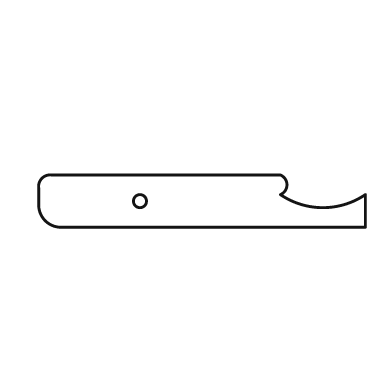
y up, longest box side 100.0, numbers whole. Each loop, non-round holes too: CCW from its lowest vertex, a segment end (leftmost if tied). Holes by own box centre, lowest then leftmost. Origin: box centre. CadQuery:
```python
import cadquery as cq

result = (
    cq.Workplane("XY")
    .moveTo(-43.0, -8.0)
    .lineTo(50.0, -8.0)
    .lineTo(50.0, 2.0)
    .threePointArc((37.0, -2.0), (24.0, 2.0))
    .threePointArc((26.0, 5.0), (24.0, 8.0))
    .lineTo(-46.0, 8.0)
    .threePointArc((-49.0, 7.0), (-50.0, 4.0))
    .lineTo(-50.0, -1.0)
    .threePointArc((-48.0, -6.0), (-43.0, -8.0))
    .close()
    .moveTo(-19.0, 0.0)
    .circle(2.0)
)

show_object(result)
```